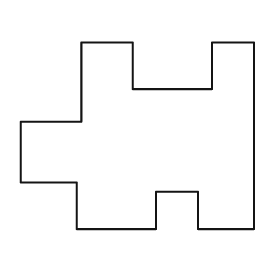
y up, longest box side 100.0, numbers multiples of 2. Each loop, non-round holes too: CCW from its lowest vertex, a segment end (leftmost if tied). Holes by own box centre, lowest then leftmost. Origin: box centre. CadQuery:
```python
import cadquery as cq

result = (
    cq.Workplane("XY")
    .moveTo(-26.0, -40.0)
    .lineTo(8.0, -40.0)
    .lineTo(8.0, -24.0)
    .lineTo(26.0, -24.0)
    .lineTo(26.0, -40.0)
    .lineTo(50.0, -40.0)
    .lineTo(50.0, 40.0)
    .lineTo(32.0, 40.0)
    .lineTo(32.0, 20.0)
    .lineTo(-2.0, 20.0)
    .lineTo(-2.0, 40.0)
    .lineTo(-24.0, 40.0)
    .lineTo(-24.0, 6.0)
    .lineTo(-50.0, 6.0)
    .lineTo(-50.0, -20.0)
    .lineTo(-26.0, -20.0)
    .close()
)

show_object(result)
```